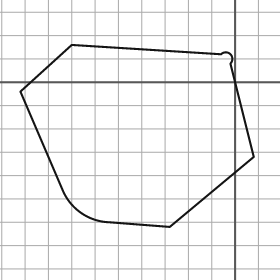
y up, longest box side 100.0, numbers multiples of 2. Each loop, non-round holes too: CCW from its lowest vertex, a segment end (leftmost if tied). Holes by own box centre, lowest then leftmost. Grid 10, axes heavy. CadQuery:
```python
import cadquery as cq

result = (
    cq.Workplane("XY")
    .moveTo(-28.0, -62.0)
    .lineTo(8.0, -32.0)
    .lineTo(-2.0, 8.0)
    .threePointArc((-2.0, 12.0), (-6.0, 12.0))
    .lineTo(-70.0, 16.0)
    .lineTo(-92.0, -4.0)
    .lineTo(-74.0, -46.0)
    .threePointArc((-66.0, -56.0), (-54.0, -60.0))
    .close()
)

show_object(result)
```